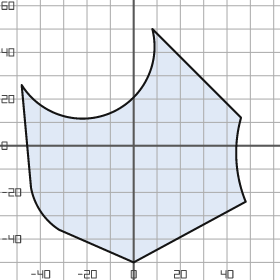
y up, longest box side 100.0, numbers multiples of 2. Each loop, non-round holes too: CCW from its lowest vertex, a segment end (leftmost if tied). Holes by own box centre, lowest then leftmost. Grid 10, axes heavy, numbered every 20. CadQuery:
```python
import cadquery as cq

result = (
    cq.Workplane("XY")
    .moveTo(0.0, -50.0)
    .lineTo(48.0, -24.0)
    .threePointArc((44.0, -6.0), (46.0, 12.0))
    .lineTo(8.0, 50.0)
    .threePointArc((-10.0, 14.0), (-48.0, 26.0))
    .lineTo(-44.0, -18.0)
    .threePointArc((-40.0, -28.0), (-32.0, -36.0))
    .close()
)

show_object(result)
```